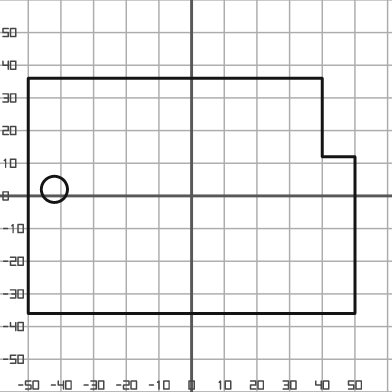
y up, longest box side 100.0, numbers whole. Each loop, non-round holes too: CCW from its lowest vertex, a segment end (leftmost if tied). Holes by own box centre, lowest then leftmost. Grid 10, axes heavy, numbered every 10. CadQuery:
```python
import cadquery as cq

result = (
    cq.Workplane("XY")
    .moveTo(-50.0, -36.0)
    .lineTo(50.0, -36.0)
    .lineTo(50.0, 12.0)
    .lineTo(40.0, 12.0)
    .lineTo(40.0, 36.0)
    .lineTo(-50.0, 36.0)
    .close()
    .moveTo(-42.0, 2.0)
    .circle(4.0)
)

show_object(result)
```